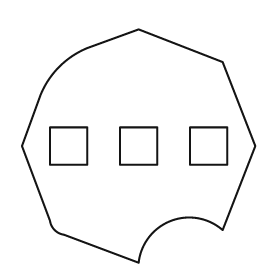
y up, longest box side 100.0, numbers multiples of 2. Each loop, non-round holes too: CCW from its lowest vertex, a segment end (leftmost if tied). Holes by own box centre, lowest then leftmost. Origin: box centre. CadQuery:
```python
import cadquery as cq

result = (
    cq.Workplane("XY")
    .moveTo(0.0, -50.0)
    .threePointArc((14.0, -32.0), (36.0, -36.0))
    .lineTo(50.0, 0.0)
    .lineTo(36.0, 36.0)
    .lineTo(0.0, 50.0)
    .lineTo(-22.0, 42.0)
    .threePointArc((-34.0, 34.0), (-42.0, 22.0))
    .lineTo(-50.0, 0.0)
    .lineTo(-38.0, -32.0)
    .threePointArc((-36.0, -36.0), (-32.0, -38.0))
    .close()
    .moveTo(-38.0, -8.0)
    .lineTo(-22.0, -8.0)
    .lineTo(-22.0, 8.0)
    .lineTo(-38.0, 8.0)
    .close()
    .moveTo(-8.0, -8.0)
    .lineTo(8.0, -8.0)
    .lineTo(8.0, 8.0)
    .lineTo(-8.0, 8.0)
    .close()
    .moveTo(22.0, -8.0)
    .lineTo(38.0, -8.0)
    .lineTo(38.0, 8.0)
    .lineTo(22.0, 8.0)
    .close()
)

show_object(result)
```